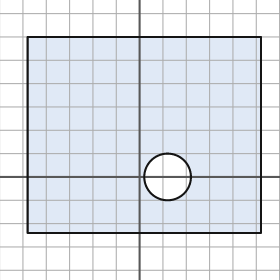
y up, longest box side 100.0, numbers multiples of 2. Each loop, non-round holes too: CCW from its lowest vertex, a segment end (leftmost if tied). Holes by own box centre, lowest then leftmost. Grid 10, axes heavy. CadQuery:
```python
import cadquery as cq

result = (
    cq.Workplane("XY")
    .moveTo(-48.0, -24.0)
    .lineTo(52.0, -24.0)
    .lineTo(52.0, 60.0)
    .lineTo(-48.0, 60.0)
    .close()
    .moveTo(12.0, 0.0)
    .circle(10.0)
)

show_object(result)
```